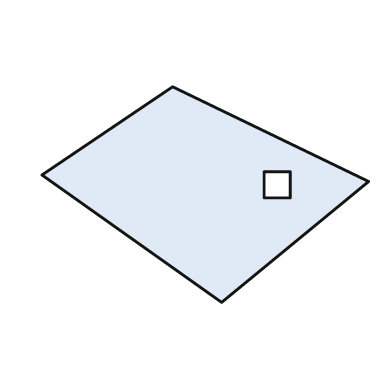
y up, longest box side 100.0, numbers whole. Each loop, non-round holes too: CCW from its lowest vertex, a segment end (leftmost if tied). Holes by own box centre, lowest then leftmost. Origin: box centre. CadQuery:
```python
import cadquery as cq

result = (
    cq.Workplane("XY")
    .moveTo(5.0, -33.0)
    .lineTo(50.0, 4.0)
    .lineTo(-10.0, 33.0)
    .lineTo(-50.0, 6.0)
    .close()
    .moveTo(18.0, -1.0)
    .lineTo(26.0, -1.0)
    .lineTo(26.0, 7.0)
    .lineTo(18.0, 7.0)
    .close()
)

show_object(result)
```